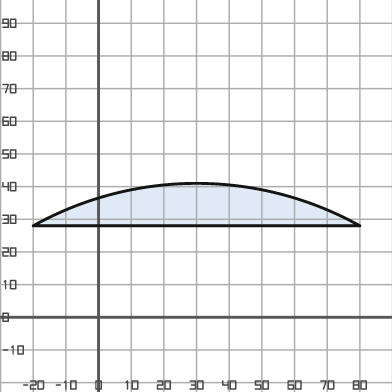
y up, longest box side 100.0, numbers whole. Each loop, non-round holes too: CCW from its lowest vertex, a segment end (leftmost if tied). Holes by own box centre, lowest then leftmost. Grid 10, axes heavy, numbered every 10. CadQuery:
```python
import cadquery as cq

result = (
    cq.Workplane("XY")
    .moveTo(-20.0, 28.0)
    .lineTo(80.0, 28.0)
    .threePointArc((30.0, 41.0), (-20.0, 28.0))
    .close()
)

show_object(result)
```